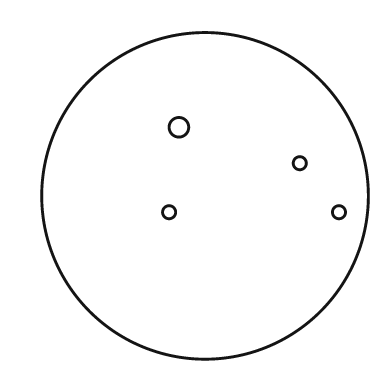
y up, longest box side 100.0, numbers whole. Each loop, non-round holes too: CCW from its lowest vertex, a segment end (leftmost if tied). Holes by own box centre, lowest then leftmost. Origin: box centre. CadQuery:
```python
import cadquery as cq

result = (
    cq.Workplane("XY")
    .moveTo(0.0, 0.0)
    .circle(50.0)
    .moveTo(-11.0, -5.0)
    .circle(2.0)
    .moveTo(41.0, -5.0)
    .circle(2.0)
    .moveTo(29.0, 10.0)
    .circle(2.0)
    .moveTo(-8.0, 21.0)
    .circle(3.0)
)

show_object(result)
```